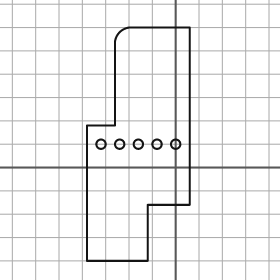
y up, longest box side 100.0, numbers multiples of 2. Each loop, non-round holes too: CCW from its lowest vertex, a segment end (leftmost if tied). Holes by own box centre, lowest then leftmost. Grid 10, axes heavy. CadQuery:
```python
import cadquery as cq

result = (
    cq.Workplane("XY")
    .moveTo(-38.0, -40.0)
    .lineTo(-12.0, -40.0)
    .lineTo(-12.0, -16.0)
    .lineTo(6.0, -16.0)
    .lineTo(6.0, 60.0)
    .lineTo(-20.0, 60.0)
    .threePointArc((-24.0, 58.0), (-26.0, 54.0))
    .lineTo(-26.0, 18.0)
    .lineTo(-38.0, 18.0)
    .close()
    .moveTo(-32.0, 10.0)
    .circle(2.0)
    .moveTo(-24.0, 10.0)
    .circle(2.0)
    .moveTo(-16.0, 10.0)
    .circle(2.0)
    .moveTo(-8.0, 10.0)
    .circle(2.0)
    .moveTo(0.0, 10.0)
    .circle(2.0)
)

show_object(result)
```